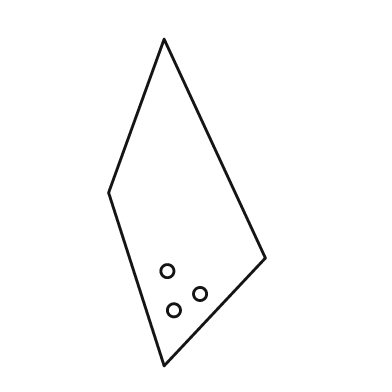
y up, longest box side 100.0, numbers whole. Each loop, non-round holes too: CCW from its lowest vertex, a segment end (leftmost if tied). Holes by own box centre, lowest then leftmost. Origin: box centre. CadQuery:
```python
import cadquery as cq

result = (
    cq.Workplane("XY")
    .moveTo(-7.0, -50.0)
    .lineTo(24.0, -17.0)
    .lineTo(-7.0, 50.0)
    .lineTo(-24.0, 3.0)
    .close()
    .moveTo(-4.0, -33.0)
    .circle(2.0)
    .moveTo(4.0, -28.0)
    .circle(2.0)
    .moveTo(-6.0, -21.0)
    .circle(2.0)
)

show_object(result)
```